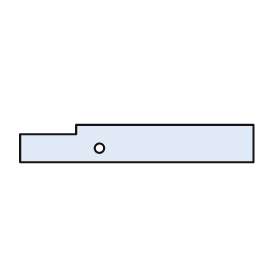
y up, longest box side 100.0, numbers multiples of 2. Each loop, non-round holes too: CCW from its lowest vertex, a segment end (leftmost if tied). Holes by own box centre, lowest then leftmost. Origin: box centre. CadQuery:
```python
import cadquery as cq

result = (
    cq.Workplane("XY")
    .moveTo(-50.0, -8.0)
    .lineTo(50.0, -8.0)
    .lineTo(50.0, 8.0)
    .lineTo(-26.0, 8.0)
    .lineTo(-26.0, 4.0)
    .lineTo(-50.0, 4.0)
    .close()
    .moveTo(-16.0, -2.0)
    .circle(2.0)
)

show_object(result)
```